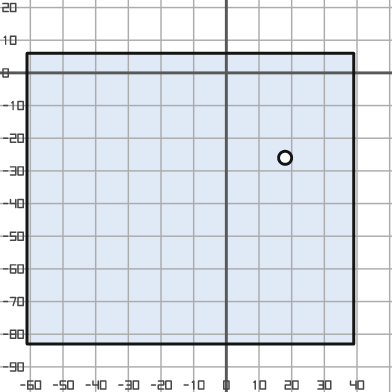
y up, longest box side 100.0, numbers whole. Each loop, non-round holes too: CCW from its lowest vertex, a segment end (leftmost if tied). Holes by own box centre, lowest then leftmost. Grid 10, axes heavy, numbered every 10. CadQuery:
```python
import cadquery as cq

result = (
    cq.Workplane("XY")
    .moveTo(-61.0, -83.0)
    .lineTo(39.0, -83.0)
    .lineTo(39.0, 6.0)
    .lineTo(-61.0, 6.0)
    .close()
    .moveTo(18.0, -26.0)
    .circle(2.0)
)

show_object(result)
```